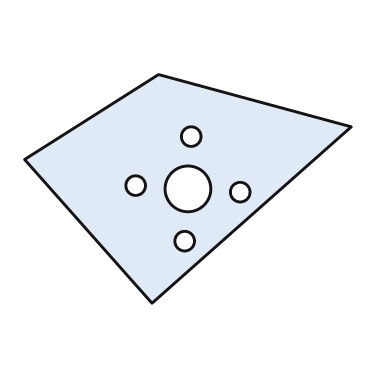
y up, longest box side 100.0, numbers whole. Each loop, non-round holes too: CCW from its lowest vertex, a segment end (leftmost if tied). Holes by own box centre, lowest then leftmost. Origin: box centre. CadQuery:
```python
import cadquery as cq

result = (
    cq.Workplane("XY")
    .moveTo(-11.0, -35.0)
    .lineTo(50.0, 19.0)
    .lineTo(-9.0, 35.0)
    .lineTo(-50.0, 9.0)
    .close()
    .moveTo(-1.0, -16.0)
    .circle(3.0)
    .moveTo(16.0, -1.0)
    .circle(3.0)
    .moveTo(0.0, 0.0)
    .circle(7.0)
    .moveTo(-16.0, 1.0)
    .circle(3.0)
    .moveTo(1.0, 16.0)
    .circle(3.0)
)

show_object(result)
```